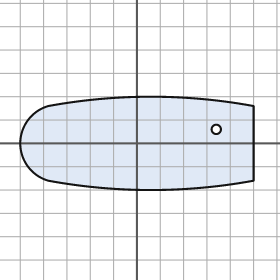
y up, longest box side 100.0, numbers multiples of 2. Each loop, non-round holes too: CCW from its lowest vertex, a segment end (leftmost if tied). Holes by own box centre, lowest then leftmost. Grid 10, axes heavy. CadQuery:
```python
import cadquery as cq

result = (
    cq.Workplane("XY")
    .moveTo(-38.0, -16.0)
    .threePointArc((6.0, -20.0), (50.0, -16.0))
    .lineTo(50.0, 16.0)
    .threePointArc((6.0, 20.0), (-38.0, 16.0))
    .threePointArc((-50.0, 0.0), (-38.0, -16.0))
    .close()
    .moveTo(34.0, 6.0)
    .circle(2.0)
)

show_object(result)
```